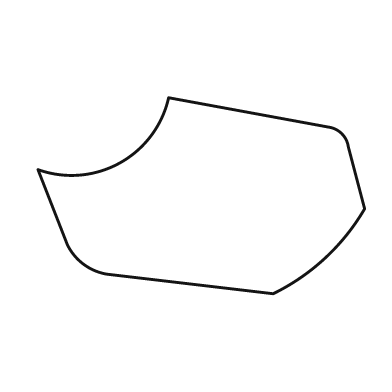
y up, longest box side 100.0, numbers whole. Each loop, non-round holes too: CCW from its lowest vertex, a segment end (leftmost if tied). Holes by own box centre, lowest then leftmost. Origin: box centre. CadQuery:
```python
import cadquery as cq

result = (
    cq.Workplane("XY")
    .moveTo(22.0, -30.0)
    .threePointArc((38.0, -19.0), (50.0, -4.0))
    .lineTo(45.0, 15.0)
    .threePointArc((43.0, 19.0), (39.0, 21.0))
    .lineTo(-10.0, 30.0)
    .threePointArc((-25.0, 10.0), (-50.0, 8.0))
    .lineTo(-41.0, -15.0)
    .threePointArc((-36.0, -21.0), (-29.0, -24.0))
    .close()
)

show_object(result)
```